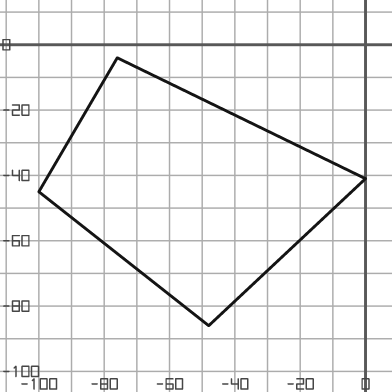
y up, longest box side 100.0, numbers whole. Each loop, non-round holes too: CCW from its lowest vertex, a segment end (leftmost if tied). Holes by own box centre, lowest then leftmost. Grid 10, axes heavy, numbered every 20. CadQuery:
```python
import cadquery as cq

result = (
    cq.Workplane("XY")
    .moveTo(-48.0, -86.0)
    .lineTo(0.0, -41.0)
    .lineTo(-76.0, -4.0)
    .lineTo(-100.0, -45.0)
    .close()
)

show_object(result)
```